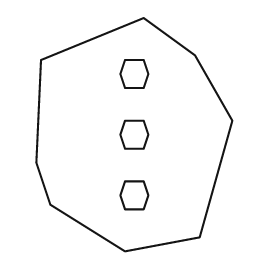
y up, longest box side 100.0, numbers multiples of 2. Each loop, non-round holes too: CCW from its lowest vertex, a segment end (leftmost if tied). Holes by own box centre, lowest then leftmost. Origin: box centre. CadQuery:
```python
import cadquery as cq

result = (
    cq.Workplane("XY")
    .moveTo(-4.0, -50.0)
    .lineTo(28.0, -44.0)
    .lineTo(42.0, 6.0)
    .lineTo(26.0, 34.0)
    .lineTo(4.0, 50.0)
    .lineTo(-40.0, 32.0)
    .lineTo(-42.0, -12.0)
    .lineTo(-36.0, -30.0)
    .close()
    .moveTo(-4.0, -32.0)
    .lineTo(4.0, -32.0)
    .lineTo(6.0, -26.0)
    .lineTo(4.0, -20.0)
    .lineTo(-4.0, -20.0)
    .lineTo(-6.0, -26.0)
    .close()
    .moveTo(-4.0, -6.0)
    .lineTo(4.0, -6.0)
    .lineTo(6.0, 0.0)
    .lineTo(4.0, 6.0)
    .lineTo(-4.0, 6.0)
    .lineTo(-6.0, 0.0)
    .close()
    .moveTo(-4.0, 20.0)
    .lineTo(4.0, 20.0)
    .lineTo(6.0, 26.0)
    .lineTo(4.0, 32.0)
    .lineTo(-4.0, 32.0)
    .lineTo(-6.0, 26.0)
    .close()
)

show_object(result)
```